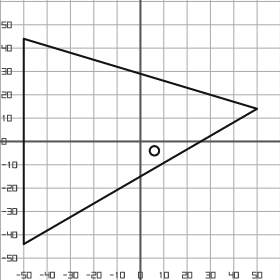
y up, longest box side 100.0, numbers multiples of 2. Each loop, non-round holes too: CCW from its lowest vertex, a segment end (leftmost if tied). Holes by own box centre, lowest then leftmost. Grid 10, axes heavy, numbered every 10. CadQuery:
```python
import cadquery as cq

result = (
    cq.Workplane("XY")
    .moveTo(-50.0, -44.0)
    .lineTo(50.0, 14.0)
    .lineTo(-50.0, 44.0)
    .close()
    .moveTo(6.0, -4.0)
    .circle(2.0)
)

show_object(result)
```